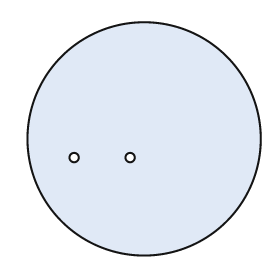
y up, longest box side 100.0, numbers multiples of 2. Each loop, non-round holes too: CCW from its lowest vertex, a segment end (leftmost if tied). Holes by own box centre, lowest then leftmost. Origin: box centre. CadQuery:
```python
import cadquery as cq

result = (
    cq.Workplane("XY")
    .moveTo(0.0, 0.0)
    .circle(50.0)
    .moveTo(-30.0, -8.0)
    .circle(2.0)
    .moveTo(-6.0, -8.0)
    .circle(2.0)
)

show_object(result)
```